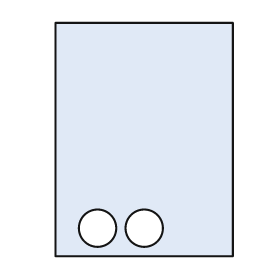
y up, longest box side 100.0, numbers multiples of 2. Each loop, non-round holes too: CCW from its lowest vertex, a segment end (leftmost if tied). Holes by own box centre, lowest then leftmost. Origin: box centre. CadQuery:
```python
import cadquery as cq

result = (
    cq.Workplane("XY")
    .moveTo(-38.0, -50.0)
    .lineTo(38.0, -50.0)
    .lineTo(38.0, 50.0)
    .lineTo(-38.0, 50.0)
    .close()
    .moveTo(-20.0, -38.0)
    .circle(8.0)
    .moveTo(0.0, -38.0)
    .circle(8.0)
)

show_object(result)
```